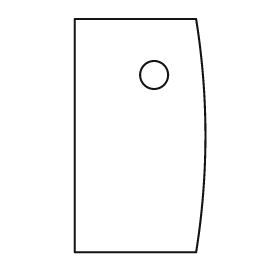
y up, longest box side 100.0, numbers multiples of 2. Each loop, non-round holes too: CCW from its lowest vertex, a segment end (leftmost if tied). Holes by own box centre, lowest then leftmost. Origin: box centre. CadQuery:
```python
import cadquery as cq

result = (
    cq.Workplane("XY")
    .moveTo(-28.0, -50.0)
    .lineTo(24.0, -50.0)
    .threePointArc((28.0, 0.0), (24.0, 50.0))
    .lineTo(-28.0, 50.0)
    .close()
    .moveTo(6.0, 26.0)
    .circle(6.0)
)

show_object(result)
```